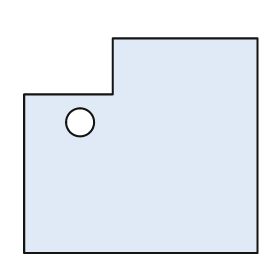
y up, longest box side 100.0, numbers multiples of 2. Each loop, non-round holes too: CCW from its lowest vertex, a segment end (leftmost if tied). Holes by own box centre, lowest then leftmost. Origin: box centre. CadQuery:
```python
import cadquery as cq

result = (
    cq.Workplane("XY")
    .moveTo(-50.0, -46.0)
    .lineTo(50.0, -46.0)
    .lineTo(50.0, 46.0)
    .lineTo(-12.0, 46.0)
    .lineTo(-12.0, 22.0)
    .lineTo(-50.0, 22.0)
    .close()
    .moveTo(-26.0, 10.0)
    .circle(6.0)
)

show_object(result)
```